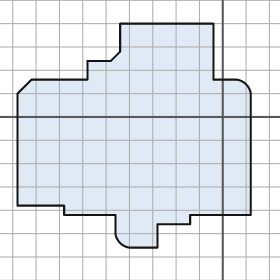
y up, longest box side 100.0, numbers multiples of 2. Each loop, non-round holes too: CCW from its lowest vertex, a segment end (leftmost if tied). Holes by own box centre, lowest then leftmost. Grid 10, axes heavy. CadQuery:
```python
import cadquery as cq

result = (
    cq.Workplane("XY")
    .moveTo(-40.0, -56.0)
    .lineTo(-28.0, -56.0)
    .lineTo(-28.0, -46.0)
    .lineTo(-14.0, -46.0)
    .lineTo(-14.0, -42.0)
    .lineTo(12.0, -42.0)
    .lineTo(12.0, 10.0)
    .threePointArc((10.0, 14.0), (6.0, 16.0))
    .lineTo(-4.0, 16.0)
    .lineTo(-4.0, 40.0)
    .lineTo(-44.0, 40.0)
    .lineTo(-44.0, 28.0)
    .lineTo(-48.0, 24.0)
    .lineTo(-58.0, 24.0)
    .lineTo(-58.0, 16.0)
    .lineTo(-82.0, 16.0)
    .lineTo(-88.0, 10.0)
    .lineTo(-88.0, -38.0)
    .lineTo(-68.0, -38.0)
    .lineTo(-68.0, -42.0)
    .lineTo(-46.0, -42.0)
    .lineTo(-46.0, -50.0)
    .threePointArc((-44.0, -54.0), (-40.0, -56.0))
    .close()
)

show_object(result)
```